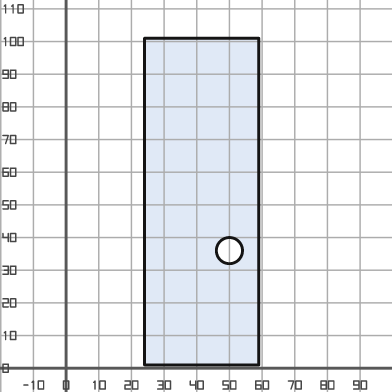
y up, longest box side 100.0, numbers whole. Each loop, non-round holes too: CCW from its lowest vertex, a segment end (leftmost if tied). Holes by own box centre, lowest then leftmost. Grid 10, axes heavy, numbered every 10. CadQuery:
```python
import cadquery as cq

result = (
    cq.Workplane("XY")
    .moveTo(24.0, 1.0)
    .lineTo(59.0, 1.0)
    .lineTo(59.0, 101.0)
    .lineTo(24.0, 101.0)
    .close()
    .moveTo(50.0, 36.0)
    .circle(4.0)
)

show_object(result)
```